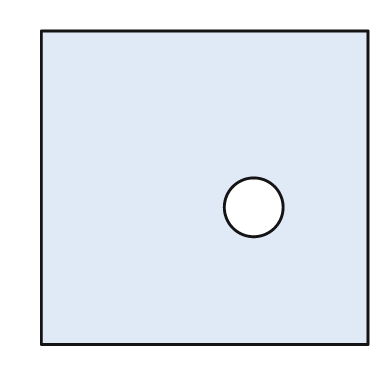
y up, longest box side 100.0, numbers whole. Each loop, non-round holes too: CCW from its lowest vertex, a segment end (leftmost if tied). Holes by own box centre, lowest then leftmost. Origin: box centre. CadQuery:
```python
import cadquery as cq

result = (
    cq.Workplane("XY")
    .moveTo(-50.0, -48.0)
    .lineTo(50.0, -48.0)
    .lineTo(50.0, 48.0)
    .lineTo(-50.0, 48.0)
    .close()
    .moveTo(15.0, -6.0)
    .circle(9.0)
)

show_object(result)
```